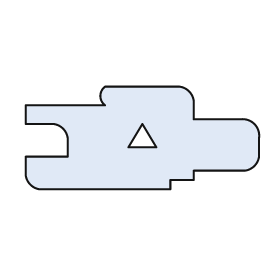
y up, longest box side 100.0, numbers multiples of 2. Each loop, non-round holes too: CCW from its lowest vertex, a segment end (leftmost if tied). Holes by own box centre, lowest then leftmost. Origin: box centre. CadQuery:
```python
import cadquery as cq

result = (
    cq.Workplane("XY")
    .moveTo(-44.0, -22.0)
    .lineTo(12.0, -22.0)
    .lineTo(12.0, -18.0)
    .lineTo(22.0, -18.0)
    .lineTo(22.0, -14.0)
    .lineTo(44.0, -14.0)
    .threePointArc((48.0, -12.0), (50.0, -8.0))
    .lineTo(50.0, 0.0)
    .threePointArc((48.0, 6.0), (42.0, 8.0))
    .lineTo(22.0, 8.0)
    .lineTo(22.0, 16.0)
    .threePointArc((20.0, 20.0), (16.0, 22.0))
    .lineTo(-16.0, 22.0)
    .threePointArc((-18.0, 18.0), (-16.0, 14.0))
    .lineTo(-50.0, 14.0)
    .lineTo(-50.0, 6.0)
    .lineTo(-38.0, 6.0)
    .threePointArc((-34.0, 4.0), (-32.0, 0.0))
    .lineTo(-32.0, -8.0)
    .lineTo(-50.0, -8.0)
    .lineTo(-50.0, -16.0)
    .threePointArc((-48.0, -20.0), (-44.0, -22.0))
    .close()
    .moveTo(-6.0, -4.0)
    .lineTo(6.0, -4.0)
    .lineTo(0.0, 6.0)
    .close()
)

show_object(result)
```